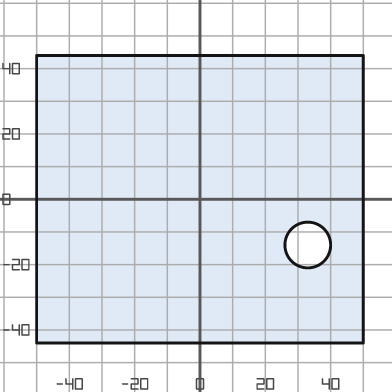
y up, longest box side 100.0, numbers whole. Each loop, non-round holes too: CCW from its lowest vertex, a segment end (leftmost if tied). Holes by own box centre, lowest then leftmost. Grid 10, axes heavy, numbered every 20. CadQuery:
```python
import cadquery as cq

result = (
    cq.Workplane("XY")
    .moveTo(-50.0, -44.0)
    .lineTo(50.0, -44.0)
    .lineTo(50.0, 44.0)
    .lineTo(-50.0, 44.0)
    .close()
    .moveTo(33.0, -14.0)
    .circle(7.0)
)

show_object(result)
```